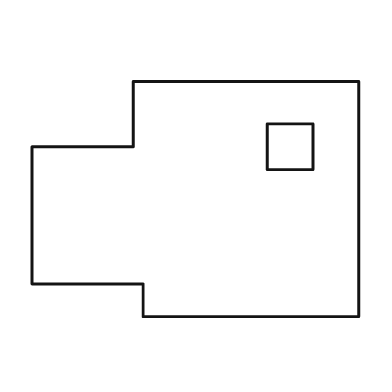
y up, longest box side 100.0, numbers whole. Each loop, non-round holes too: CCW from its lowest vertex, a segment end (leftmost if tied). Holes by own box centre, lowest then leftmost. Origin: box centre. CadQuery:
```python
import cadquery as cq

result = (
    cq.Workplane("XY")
    .moveTo(-16.0, -36.0)
    .lineTo(50.0, -36.0)
    .lineTo(50.0, 36.0)
    .lineTo(-19.0, 36.0)
    .lineTo(-19.0, 16.0)
    .lineTo(-50.0, 16.0)
    .lineTo(-50.0, -26.0)
    .lineTo(-16.0, -26.0)
    .close()
    .moveTo(22.0, 9.0)
    .lineTo(36.0, 9.0)
    .lineTo(36.0, 23.0)
    .lineTo(22.0, 23.0)
    .close()
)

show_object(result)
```